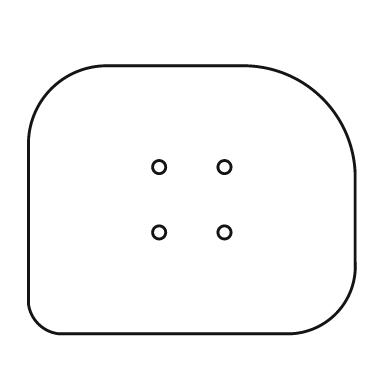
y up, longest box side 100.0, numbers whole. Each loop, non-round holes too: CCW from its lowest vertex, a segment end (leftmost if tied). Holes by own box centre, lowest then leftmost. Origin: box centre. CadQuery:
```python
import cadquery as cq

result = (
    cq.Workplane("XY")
    .moveTo(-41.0, -41.0)
    .lineTo(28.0, -41.0)
    .threePointArc((44.0, -35.0), (50.0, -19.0))
    .lineTo(50.0, 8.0)
    .threePointArc((40.0, 31.0), (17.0, 41.0))
    .lineTo(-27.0, 41.0)
    .threePointArc((-43.0, 34.0), (-50.0, 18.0))
    .lineTo(-50.0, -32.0)
    .threePointArc((-47.0, -38.0), (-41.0, -41.0))
    .close()
    .moveTo(-10.0, -10.0)
    .circle(2.0)
    .moveTo(10.0, -10.0)
    .circle(2.0)
    .moveTo(-10.0, 10.0)
    .circle(2.0)
    .moveTo(10.0, 10.0)
    .circle(2.0)
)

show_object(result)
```